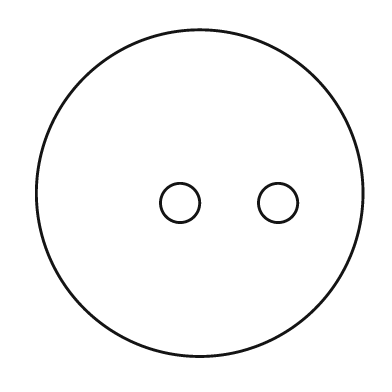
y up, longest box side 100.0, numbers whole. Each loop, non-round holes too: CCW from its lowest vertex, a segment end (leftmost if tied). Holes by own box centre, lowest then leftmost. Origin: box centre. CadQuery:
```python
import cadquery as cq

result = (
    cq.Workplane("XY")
    .moveTo(0.0, 0.0)
    .circle(50.0)
    .moveTo(-6.0, -3.0)
    .circle(6.0)
    .moveTo(24.0, -3.0)
    .circle(6.0)
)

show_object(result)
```